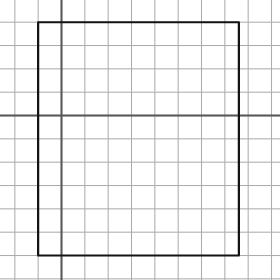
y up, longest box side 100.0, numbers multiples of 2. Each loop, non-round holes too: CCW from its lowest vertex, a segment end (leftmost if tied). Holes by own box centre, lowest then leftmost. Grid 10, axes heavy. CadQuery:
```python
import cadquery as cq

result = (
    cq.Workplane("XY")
    .moveTo(-10.0, -60.0)
    .lineTo(76.0, -60.0)
    .lineTo(76.0, 40.0)
    .lineTo(-10.0, 40.0)
    .close()
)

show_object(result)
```